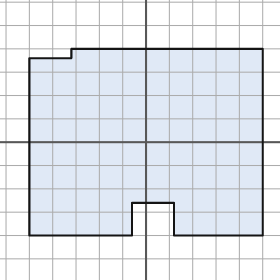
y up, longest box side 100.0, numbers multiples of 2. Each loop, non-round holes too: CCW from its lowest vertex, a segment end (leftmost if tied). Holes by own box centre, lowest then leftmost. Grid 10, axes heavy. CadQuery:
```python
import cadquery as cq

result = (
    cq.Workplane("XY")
    .moveTo(-50.0, -40.0)
    .lineTo(-6.0, -40.0)
    .lineTo(-6.0, -26.0)
    .lineTo(12.0, -26.0)
    .lineTo(12.0, -40.0)
    .lineTo(50.0, -40.0)
    .lineTo(50.0, 40.0)
    .lineTo(-32.0, 40.0)
    .lineTo(-32.0, 36.0)
    .lineTo(-50.0, 36.0)
    .close()
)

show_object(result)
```